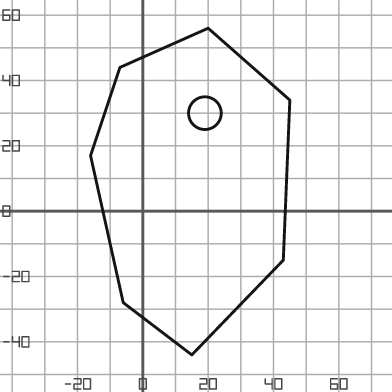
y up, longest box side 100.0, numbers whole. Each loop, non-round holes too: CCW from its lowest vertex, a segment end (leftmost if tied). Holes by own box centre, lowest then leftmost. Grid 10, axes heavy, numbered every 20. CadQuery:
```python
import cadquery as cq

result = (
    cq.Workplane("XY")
    .moveTo(15.0, -44.0)
    .lineTo(43.0, -15.0)
    .lineTo(45.0, 34.0)
    .lineTo(20.0, 56.0)
    .lineTo(-7.0, 44.0)
    .lineTo(-16.0, 17.0)
    .lineTo(-6.0, -28.0)
    .close()
    .moveTo(19.0, 30.0)
    .circle(5.0)
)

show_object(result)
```